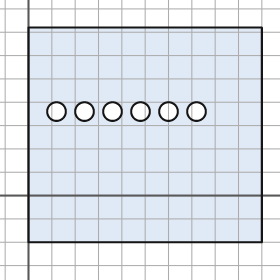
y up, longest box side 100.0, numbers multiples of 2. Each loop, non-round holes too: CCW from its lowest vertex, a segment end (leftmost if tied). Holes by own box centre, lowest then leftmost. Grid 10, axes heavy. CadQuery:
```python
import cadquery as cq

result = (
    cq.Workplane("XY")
    .moveTo(0.0, -20.0)
    .lineTo(100.0, -20.0)
    .lineTo(100.0, 72.0)
    .lineTo(0.0, 72.0)
    .close()
    .moveTo(12.0, 36.0)
    .circle(4.0)
    .moveTo(24.0, 36.0)
    .circle(4.0)
    .moveTo(36.0, 36.0)
    .circle(4.0)
    .moveTo(48.0, 36.0)
    .circle(4.0)
    .moveTo(60.0, 36.0)
    .circle(4.0)
    .moveTo(72.0, 36.0)
    .circle(4.0)
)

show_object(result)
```